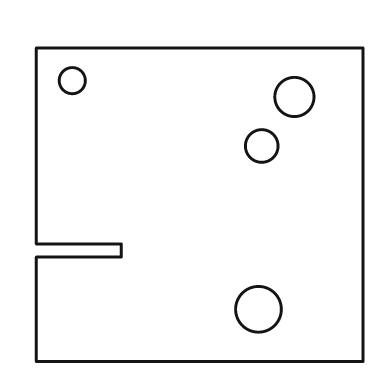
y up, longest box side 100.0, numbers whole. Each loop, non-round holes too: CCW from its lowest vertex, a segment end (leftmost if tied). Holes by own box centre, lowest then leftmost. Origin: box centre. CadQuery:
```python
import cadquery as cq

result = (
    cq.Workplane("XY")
    .moveTo(-50.0, -48.0)
    .lineTo(50.0, -48.0)
    .lineTo(50.0, 48.0)
    .lineTo(-50.0, 48.0)
    .lineTo(-50.0, -12.0)
    .lineTo(-24.0, -12.0)
    .lineTo(-24.0, -16.0)
    .lineTo(-50.0, -16.0)
    .close()
    .moveTo(18.0, -32.0)
    .circle(7.0)
    .moveTo(19.0, 18.0)
    .circle(5.0)
    .moveTo(29.0, 33.0)
    .circle(6.0)
    .moveTo(-39.0, 38.0)
    .circle(4.0)
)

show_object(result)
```